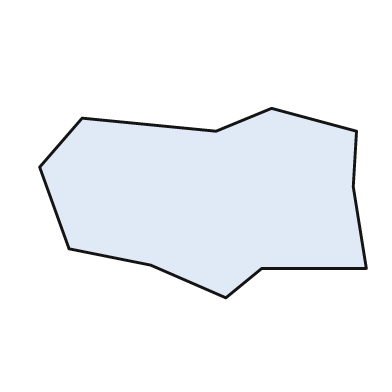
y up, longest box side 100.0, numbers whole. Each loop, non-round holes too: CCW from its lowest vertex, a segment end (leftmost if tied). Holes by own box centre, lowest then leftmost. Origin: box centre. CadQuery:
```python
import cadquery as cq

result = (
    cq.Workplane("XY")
    .moveTo(7.0, -29.0)
    .lineTo(18.0, -20.0)
    .lineTo(50.0, -20.0)
    .lineTo(46.0, 5.0)
    .lineTo(47.0, 22.0)
    .lineTo(21.0, 29.0)
    .lineTo(4.0, 22.0)
    .lineTo(-37.0, 26.0)
    .lineTo(-50.0, 11.0)
    .lineTo(-41.0, -14.0)
    .lineTo(-16.0, -19.0)
    .close()
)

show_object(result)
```